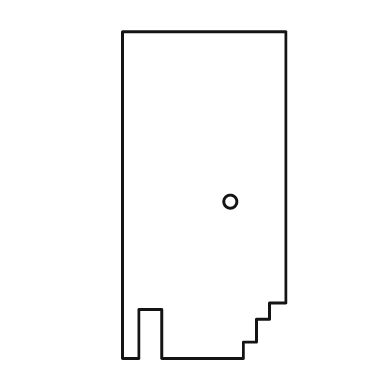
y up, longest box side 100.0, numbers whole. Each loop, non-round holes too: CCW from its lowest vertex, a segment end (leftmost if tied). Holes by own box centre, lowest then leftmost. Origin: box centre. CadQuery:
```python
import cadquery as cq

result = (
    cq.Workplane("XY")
    .moveTo(-25.0, -50.0)
    .lineTo(-20.0, -50.0)
    .lineTo(-20.0, -35.0)
    .lineTo(-13.0, -35.0)
    .lineTo(-13.0, -50.0)
    .lineTo(12.0, -50.0)
    .lineTo(12.0, -45.0)
    .lineTo(16.0, -45.0)
    .lineTo(16.0, -38.0)
    .lineTo(20.0, -38.0)
    .lineTo(20.0, -33.0)
    .lineTo(25.0, -33.0)
    .lineTo(25.0, 50.0)
    .lineTo(-25.0, 50.0)
    .close()
    .moveTo(8.0, -2.0)
    .circle(2.0)
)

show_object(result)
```